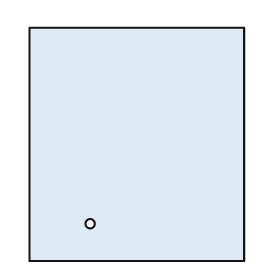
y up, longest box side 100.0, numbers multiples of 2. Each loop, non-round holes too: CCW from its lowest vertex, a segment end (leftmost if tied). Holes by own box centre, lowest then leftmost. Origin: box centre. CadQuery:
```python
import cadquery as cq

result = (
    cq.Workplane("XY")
    .moveTo(-46.0, -50.0)
    .lineTo(46.0, -50.0)
    .lineTo(46.0, 50.0)
    .lineTo(-46.0, 50.0)
    .close()
    .moveTo(-20.0, -34.0)
    .circle(2.0)
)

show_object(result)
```